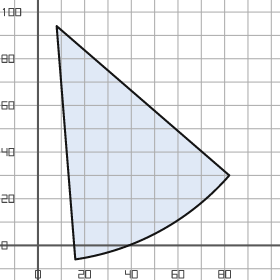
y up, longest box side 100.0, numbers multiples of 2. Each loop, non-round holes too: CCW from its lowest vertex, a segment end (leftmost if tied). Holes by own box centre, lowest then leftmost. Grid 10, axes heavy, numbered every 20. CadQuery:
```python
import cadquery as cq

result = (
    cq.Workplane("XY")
    .moveTo(16.0, -6.0)
    .threePointArc((52.0, 6.0), (82.0, 30.0))
    .lineTo(8.0, 94.0)
    .close()
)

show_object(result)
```